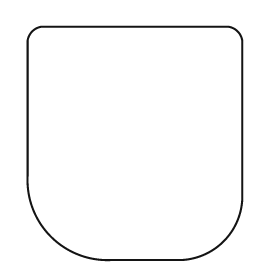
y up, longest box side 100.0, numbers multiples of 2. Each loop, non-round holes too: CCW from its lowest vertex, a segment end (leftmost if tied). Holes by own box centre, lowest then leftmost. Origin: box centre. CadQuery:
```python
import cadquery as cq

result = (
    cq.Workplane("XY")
    .moveTo(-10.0, -50.0)
    .lineTo(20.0, -50.0)
    .threePointArc((38.0, -42.0), (46.0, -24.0))
    .lineTo(46.0, 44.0)
    .threePointArc((44.0, 48.0), (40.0, 50.0))
    .lineTo(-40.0, 50.0)
    .threePointArc((-44.0, 48.0), (-46.0, 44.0))
    .lineTo(-46.0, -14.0)
    .threePointArc((-36.0, -40.0), (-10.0, -50.0))
    .close()
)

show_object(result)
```